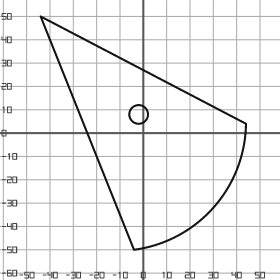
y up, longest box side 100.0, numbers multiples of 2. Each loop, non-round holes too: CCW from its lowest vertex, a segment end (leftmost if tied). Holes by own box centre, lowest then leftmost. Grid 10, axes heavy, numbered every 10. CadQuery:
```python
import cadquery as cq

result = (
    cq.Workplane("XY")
    .moveTo(-4.0, -50.0)
    .threePointArc((30.0, -32.0), (44.0, 4.0))
    .lineTo(-44.0, 50.0)
    .close()
    .moveTo(-2.0, 8.0)
    .circle(4.0)
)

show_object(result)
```